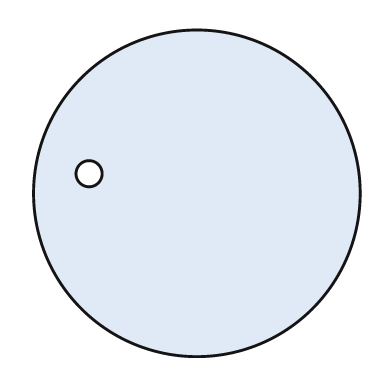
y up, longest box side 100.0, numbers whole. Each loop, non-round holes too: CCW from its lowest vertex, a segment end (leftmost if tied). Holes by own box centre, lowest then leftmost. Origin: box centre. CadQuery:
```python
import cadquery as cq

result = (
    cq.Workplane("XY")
    .moveTo(0.0, 0.0)
    .circle(50.0)
    .moveTo(-33.0, 6.0)
    .circle(4.0)
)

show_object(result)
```